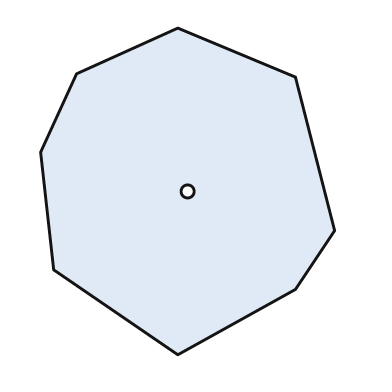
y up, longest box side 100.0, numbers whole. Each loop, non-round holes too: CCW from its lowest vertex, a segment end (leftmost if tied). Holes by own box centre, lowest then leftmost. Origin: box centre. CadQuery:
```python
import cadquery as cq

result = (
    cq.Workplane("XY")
    .moveTo(-3.0, -50.0)
    .lineTo(33.0, -30.0)
    .lineTo(45.0, -12.0)
    .lineTo(33.0, 35.0)
    .lineTo(-3.0, 50.0)
    .lineTo(-34.0, 36.0)
    .lineTo(-45.0, 12.0)
    .lineTo(-41.0, -24.0)
    .close()
    .moveTo(0.0, 0.0)
    .circle(2.0)
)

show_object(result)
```